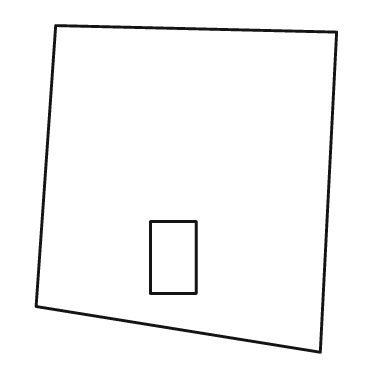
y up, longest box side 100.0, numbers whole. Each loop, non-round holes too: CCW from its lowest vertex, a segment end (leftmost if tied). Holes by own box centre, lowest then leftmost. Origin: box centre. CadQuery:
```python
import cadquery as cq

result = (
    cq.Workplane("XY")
    .moveTo(41.0, -50.0)
    .lineTo(46.0, 48.0)
    .lineTo(-40.0, 50.0)
    .lineTo(-46.0, -36.0)
    .close()
    .moveTo(-11.0, -32.0)
    .lineTo(3.0, -32.0)
    .lineTo(3.0, -10.0)
    .lineTo(-11.0, -10.0)
    .close()
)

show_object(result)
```